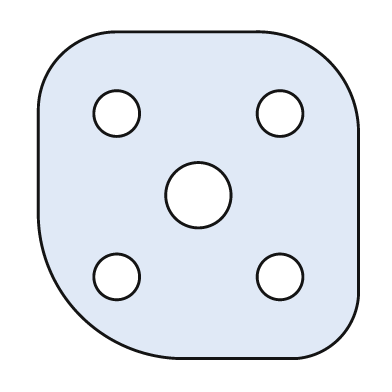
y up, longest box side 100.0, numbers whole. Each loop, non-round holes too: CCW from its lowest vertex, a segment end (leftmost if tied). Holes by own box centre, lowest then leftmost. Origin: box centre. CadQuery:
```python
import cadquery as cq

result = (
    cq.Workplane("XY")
    .moveTo(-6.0, -50.0)
    .lineTo(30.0, -50.0)
    .threePointArc((43.0, -44.0), (49.0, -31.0))
    .lineTo(49.0, 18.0)
    .threePointArc((40.0, 41.0), (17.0, 50.0))
    .lineTo(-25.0, 50.0)
    .threePointArc((-42.0, 43.0), (-49.0, 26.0))
    .lineTo(-49.0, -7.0)
    .threePointArc((-36.0, -37.0), (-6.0, -50.0))
    .close()
    .moveTo(-25.0, -25.0)
    .circle(7.0)
    .moveTo(25.0, -25.0)
    .circle(7.0)
    .moveTo(0.0, 0.0)
    .circle(10.0)
    .moveTo(-25.0, 25.0)
    .circle(7.0)
    .moveTo(25.0, 25.0)
    .circle(7.0)
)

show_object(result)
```